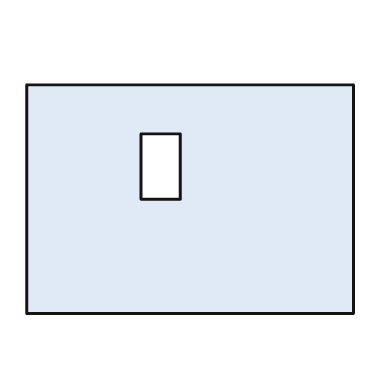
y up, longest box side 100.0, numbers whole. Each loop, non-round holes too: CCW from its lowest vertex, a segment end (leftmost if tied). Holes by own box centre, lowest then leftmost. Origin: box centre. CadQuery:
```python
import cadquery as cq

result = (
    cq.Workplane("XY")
    .moveTo(-50.0, -35.0)
    .lineTo(50.0, -35.0)
    .lineTo(50.0, 35.0)
    .lineTo(-50.0, 35.0)
    .close()
    .moveTo(-15.0, 0.0)
    .lineTo(-3.0, 0.0)
    .lineTo(-3.0, 20.0)
    .lineTo(-15.0, 20.0)
    .close()
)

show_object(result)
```